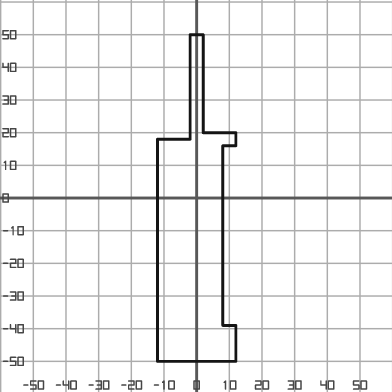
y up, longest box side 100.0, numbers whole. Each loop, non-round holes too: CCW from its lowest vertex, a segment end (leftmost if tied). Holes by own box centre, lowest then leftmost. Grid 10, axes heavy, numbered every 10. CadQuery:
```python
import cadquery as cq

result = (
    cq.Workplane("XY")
    .moveTo(-12.0, -50.0)
    .lineTo(12.0, -50.0)
    .lineTo(12.0, -39.0)
    .lineTo(8.0, -39.0)
    .lineTo(8.0, 16.0)
    .lineTo(12.0, 16.0)
    .lineTo(12.0, 20.0)
    .lineTo(2.0, 20.0)
    .lineTo(2.0, 50.0)
    .lineTo(-2.0, 50.0)
    .lineTo(-2.0, 18.0)
    .lineTo(-12.0, 18.0)
    .close()
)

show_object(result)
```